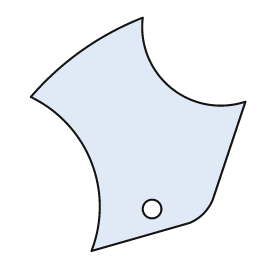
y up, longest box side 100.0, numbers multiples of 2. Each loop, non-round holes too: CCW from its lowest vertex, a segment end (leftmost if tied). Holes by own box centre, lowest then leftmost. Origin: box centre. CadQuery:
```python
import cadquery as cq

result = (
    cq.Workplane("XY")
    .moveTo(-20.0, -50.0)
    .lineTo(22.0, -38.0)
    .threePointArc((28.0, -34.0), (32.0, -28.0))
    .lineTo(46.0, 14.0)
    .threePointArc((14.0, 20.0), (2.0, 50.0))
    .threePointArc((-24.0, 36.0), (-46.0, 16.0))
    .threePointArc((-20.0, -12.0), (-20.0, -50.0))
    .close()
    .moveTo(6.0, -32.0)
    .circle(4.0)
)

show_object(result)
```